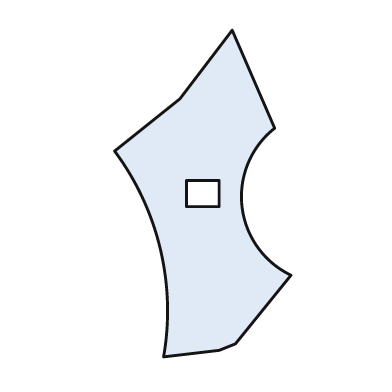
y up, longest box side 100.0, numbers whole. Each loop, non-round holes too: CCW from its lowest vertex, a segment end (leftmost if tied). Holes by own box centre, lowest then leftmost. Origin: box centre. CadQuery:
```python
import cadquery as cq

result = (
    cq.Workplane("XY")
    .moveTo(-12.0, -50.0)
    .lineTo(5.0, -48.0)
    .lineTo(10.0, -46.0)
    .lineTo(27.0, -25.0)
    .threePointArc((12.0, -4.0), (22.0, 20.0))
    .lineTo(9.0, 50.0)
    .lineTo(-7.0, 29.0)
    .lineTo(-27.0, 13.0)
    .threePointArc((-13.0, -17.0), (-12.0, -50.0))
    .close()
    .moveTo(-5.0, -4.0)
    .lineTo(5.0, -4.0)
    .lineTo(5.0, 4.0)
    .lineTo(-5.0, 4.0)
    .close()
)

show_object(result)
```